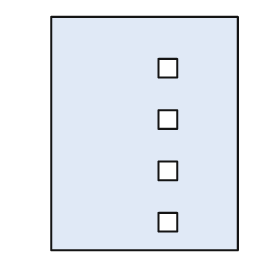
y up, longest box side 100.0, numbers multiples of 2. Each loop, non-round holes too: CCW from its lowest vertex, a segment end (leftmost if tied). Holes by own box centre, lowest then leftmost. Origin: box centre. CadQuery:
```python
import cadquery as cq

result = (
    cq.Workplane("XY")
    .moveTo(-40.0, -50.0)
    .lineTo(40.0, -50.0)
    .lineTo(40.0, 50.0)
    .lineTo(-40.0, 50.0)
    .close()
    .moveTo(6.0, -42.0)
    .lineTo(14.0, -42.0)
    .lineTo(14.0, -34.0)
    .lineTo(6.0, -34.0)
    .close()
    .moveTo(6.0, -20.0)
    .lineTo(14.0, -20.0)
    .lineTo(14.0, -12.0)
    .lineTo(6.0, -12.0)
    .close()
    .moveTo(6.0, 2.0)
    .lineTo(14.0, 2.0)
    .lineTo(14.0, 10.0)
    .lineTo(6.0, 10.0)
    .close()
    .moveTo(6.0, 24.0)
    .lineTo(14.0, 24.0)
    .lineTo(14.0, 32.0)
    .lineTo(6.0, 32.0)
    .close()
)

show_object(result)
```